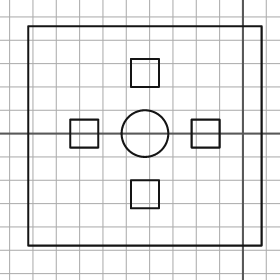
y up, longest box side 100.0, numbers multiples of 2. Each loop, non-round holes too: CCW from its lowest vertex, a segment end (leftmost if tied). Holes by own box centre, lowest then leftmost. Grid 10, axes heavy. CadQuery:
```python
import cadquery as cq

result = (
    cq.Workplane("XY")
    .moveTo(-92.0, -48.0)
    .lineTo(8.0, -48.0)
    .lineTo(8.0, 46.0)
    .lineTo(-92.0, 46.0)
    .close()
    .moveTo(-48.0, -32.0)
    .lineTo(-36.0, -32.0)
    .lineTo(-36.0, -20.0)
    .lineTo(-48.0, -20.0)
    .close()
    .moveTo(-74.0, -6.0)
    .lineTo(-62.0, -6.0)
    .lineTo(-62.0, 6.0)
    .lineTo(-74.0, 6.0)
    .close()
    .moveTo(-42.0, 0.0)
    .circle(10.0)
    .moveTo(-22.0, -6.0)
    .lineTo(-10.0, -6.0)
    .lineTo(-10.0, 6.0)
    .lineTo(-22.0, 6.0)
    .close()
    .moveTo(-48.0, 20.0)
    .lineTo(-36.0, 20.0)
    .lineTo(-36.0, 32.0)
    .lineTo(-48.0, 32.0)
    .close()
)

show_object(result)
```